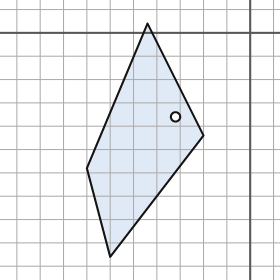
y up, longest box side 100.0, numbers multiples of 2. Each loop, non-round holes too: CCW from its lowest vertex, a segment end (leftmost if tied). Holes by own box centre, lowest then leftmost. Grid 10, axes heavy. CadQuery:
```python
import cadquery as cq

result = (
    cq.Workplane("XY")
    .moveTo(-60.0, -96.0)
    .lineTo(-20.0, -44.0)
    .lineTo(-44.0, 4.0)
    .lineTo(-70.0, -58.0)
    .close()
    .moveTo(-32.0, -36.0)
    .circle(2.0)
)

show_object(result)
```